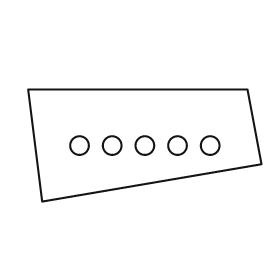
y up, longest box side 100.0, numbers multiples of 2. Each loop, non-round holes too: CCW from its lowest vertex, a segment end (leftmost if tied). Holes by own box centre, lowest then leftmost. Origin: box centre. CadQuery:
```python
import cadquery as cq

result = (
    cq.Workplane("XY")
    .moveTo(-44.0, -24.0)
    .lineTo(50.0, -8.0)
    .lineTo(44.0, 24.0)
    .lineTo(-50.0, 24.0)
    .close()
    .moveTo(-28.0, 0.0)
    .circle(4.0)
    .moveTo(-14.0, 0.0)
    .circle(4.0)
    .moveTo(0.0, 0.0)
    .circle(4.0)
    .moveTo(14.0, 0.0)
    .circle(4.0)
    .moveTo(28.0, 0.0)
    .circle(4.0)
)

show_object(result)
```